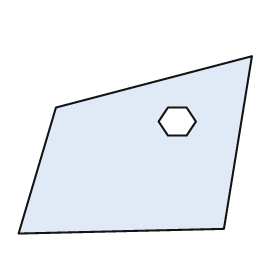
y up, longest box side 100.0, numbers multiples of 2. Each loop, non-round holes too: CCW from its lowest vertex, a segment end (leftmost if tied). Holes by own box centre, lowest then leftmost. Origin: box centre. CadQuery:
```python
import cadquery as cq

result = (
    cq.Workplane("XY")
    .moveTo(-50.0, -38.0)
    .lineTo(38.0, -36.0)
    .lineTo(50.0, 38.0)
    .lineTo(-34.0, 16.0)
    .close()
    .moveTo(14.0, 4.0)
    .lineTo(22.0, 4.0)
    .lineTo(26.0, 10.0)
    .lineTo(22.0, 16.0)
    .lineTo(14.0, 16.0)
    .lineTo(10.0, 10.0)
    .close()
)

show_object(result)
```